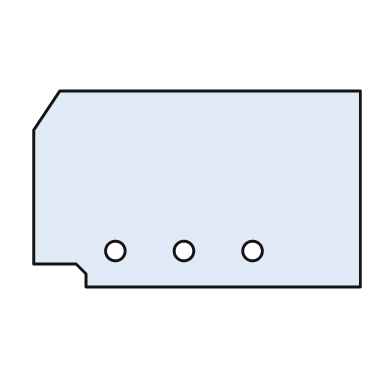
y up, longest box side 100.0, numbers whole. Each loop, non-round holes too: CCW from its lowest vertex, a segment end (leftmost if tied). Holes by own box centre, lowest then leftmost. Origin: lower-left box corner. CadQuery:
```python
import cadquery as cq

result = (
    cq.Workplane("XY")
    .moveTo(16.0, 0.0)
    .lineTo(100.0, 0.0)
    .lineTo(100.0, 60.0)
    .lineTo(8.0, 60.0)
    .lineTo(0.0, 48.0)
    .lineTo(0.0, 7.0)
    .lineTo(13.0, 7.0)
    .lineTo(16.0, 4.0)
    .close()
    .moveTo(25.0, 11.0)
    .circle(3.0)
    .moveTo(46.0, 11.0)
    .circle(3.0)
    .moveTo(67.0, 11.0)
    .circle(3.0)
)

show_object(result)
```